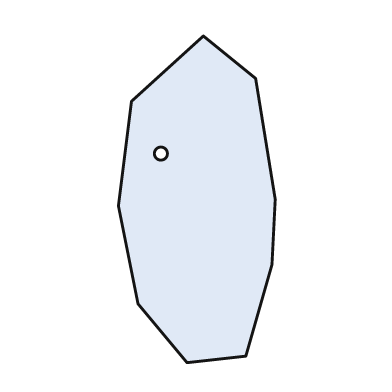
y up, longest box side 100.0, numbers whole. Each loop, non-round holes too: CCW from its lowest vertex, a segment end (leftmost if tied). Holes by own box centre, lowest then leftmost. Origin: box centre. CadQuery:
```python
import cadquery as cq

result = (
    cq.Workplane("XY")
    .moveTo(-3.0, -50.0)
    .lineTo(15.0, -48.0)
    .lineTo(23.0, -20.0)
    .lineTo(24.0, 0.0)
    .lineTo(18.0, 37.0)
    .lineTo(2.0, 50.0)
    .lineTo(-20.0, 30.0)
    .lineTo(-24.0, -2.0)
    .lineTo(-18.0, -32.0)
    .close()
    .moveTo(-11.0, 14.0)
    .circle(2.0)
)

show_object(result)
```